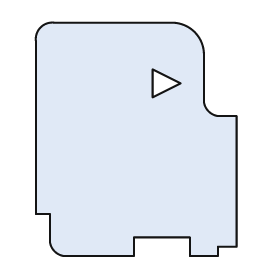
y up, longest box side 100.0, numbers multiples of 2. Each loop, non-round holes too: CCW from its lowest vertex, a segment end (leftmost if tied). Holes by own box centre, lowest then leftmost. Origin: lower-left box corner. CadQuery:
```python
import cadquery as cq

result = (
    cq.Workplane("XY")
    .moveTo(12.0, 0.0)
    .lineTo(42.0, 0.0)
    .lineTo(42.0, 8.0)
    .lineTo(66.0, 8.0)
    .lineTo(66.0, 0.0)
    .lineTo(78.0, 0.0)
    .lineTo(78.0, 4.0)
    .lineTo(86.0, 4.0)
    .lineTo(86.0, 60.0)
    .lineTo(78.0, 60.0)
    .threePointArc((74.0, 62.0), (72.0, 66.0))
    .lineTo(72.0, 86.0)
    .threePointArc((68.0, 96.0), (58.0, 100.0))
    .lineTo(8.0, 100.0)
    .threePointArc((2.0, 98.0), (0.0, 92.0))
    .lineTo(0.0, 18.0)
    .lineTo(6.0, 18.0)
    .lineTo(6.0, 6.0)
    .threePointArc((8.0, 2.0), (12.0, 0.0))
    .close()
    .moveTo(50.0, 68.0)
    .lineTo(62.0, 74.0)
    .lineTo(50.0, 80.0)
    .close()
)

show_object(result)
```